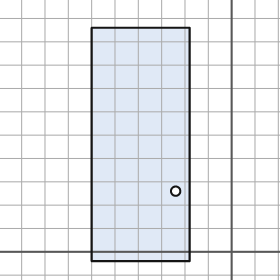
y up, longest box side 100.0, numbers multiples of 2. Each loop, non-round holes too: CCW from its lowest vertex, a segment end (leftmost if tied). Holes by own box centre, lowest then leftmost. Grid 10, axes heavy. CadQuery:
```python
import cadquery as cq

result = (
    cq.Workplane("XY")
    .moveTo(-60.0, -4.0)
    .lineTo(-18.0, -4.0)
    .lineTo(-18.0, 96.0)
    .lineTo(-60.0, 96.0)
    .close()
    .moveTo(-24.0, 26.0)
    .circle(2.0)
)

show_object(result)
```